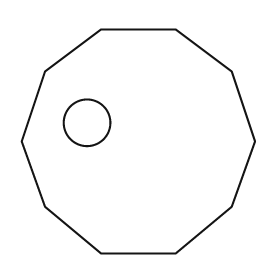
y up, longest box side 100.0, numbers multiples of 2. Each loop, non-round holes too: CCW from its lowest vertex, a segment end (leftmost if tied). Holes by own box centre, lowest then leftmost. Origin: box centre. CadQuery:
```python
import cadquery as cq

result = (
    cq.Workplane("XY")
    .moveTo(-16.0, -48.0)
    .lineTo(16.0, -48.0)
    .lineTo(40.0, -28.0)
    .lineTo(50.0, 0.0)
    .lineTo(40.0, 30.0)
    .lineTo(16.0, 48.0)
    .lineTo(-16.0, 48.0)
    .lineTo(-40.0, 30.0)
    .lineTo(-50.0, 0.0)
    .lineTo(-40.0, -28.0)
    .close()
    .moveTo(-22.0, 8.0)
    .circle(10.0)
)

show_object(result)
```